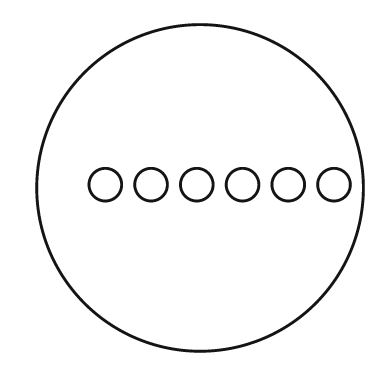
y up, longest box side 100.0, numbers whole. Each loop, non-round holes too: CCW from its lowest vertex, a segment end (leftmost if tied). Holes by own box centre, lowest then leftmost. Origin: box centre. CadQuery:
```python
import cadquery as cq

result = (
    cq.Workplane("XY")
    .moveTo(0.0, 0.0)
    .circle(50.0)
    .moveTo(-29.0, 1.0)
    .circle(5.0)
    .moveTo(-15.0, 1.0)
    .circle(5.0)
    .moveTo(-1.0, 1.0)
    .circle(5.0)
    .moveTo(13.0, 1.0)
    .circle(5.0)
    .moveTo(27.0, 1.0)
    .circle(5.0)
    .moveTo(41.0, 1.0)
    .circle(5.0)
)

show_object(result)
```